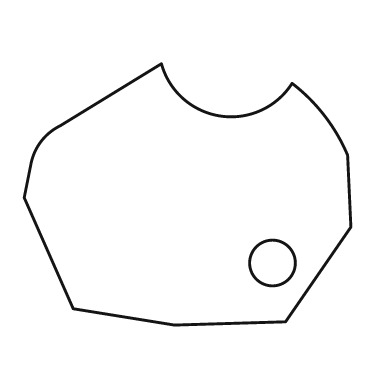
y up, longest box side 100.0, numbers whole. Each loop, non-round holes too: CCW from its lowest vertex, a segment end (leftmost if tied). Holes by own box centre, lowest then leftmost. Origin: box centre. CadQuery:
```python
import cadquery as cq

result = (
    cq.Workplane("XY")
    .moveTo(-4.0, -40.0)
    .lineTo(30.0, -39.0)
    .lineTo(50.0, -10.0)
    .lineTo(49.0, 12.0)
    .threePointArc((42.0, 24.0), (32.0, 34.0))
    .threePointArc((10.0, 24.0), (-8.0, 40.0))
    .lineTo(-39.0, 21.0)
    .threePointArc((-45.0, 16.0), (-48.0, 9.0))
    .lineTo(-50.0, -1.0)
    .lineTo(-35.0, -35.0)
    .close()
    .moveTo(26.0, -21.0)
    .circle(7.0)
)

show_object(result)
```